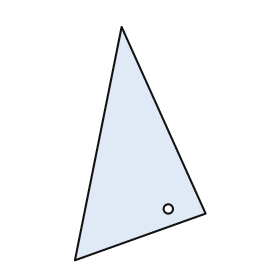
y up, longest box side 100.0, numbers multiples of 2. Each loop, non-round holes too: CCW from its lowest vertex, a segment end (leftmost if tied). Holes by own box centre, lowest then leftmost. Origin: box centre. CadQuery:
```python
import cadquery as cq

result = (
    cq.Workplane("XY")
    .moveTo(-28.0, -50.0)
    .lineTo(28.0, -30.0)
    .lineTo(-8.0, 50.0)
    .close()
    .moveTo(12.0, -28.0)
    .circle(2.0)
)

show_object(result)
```